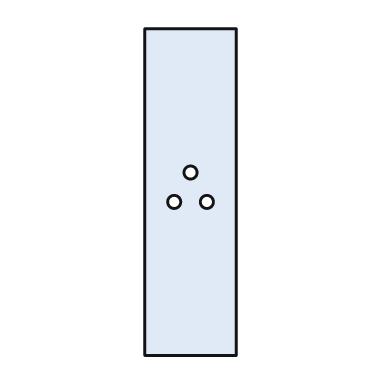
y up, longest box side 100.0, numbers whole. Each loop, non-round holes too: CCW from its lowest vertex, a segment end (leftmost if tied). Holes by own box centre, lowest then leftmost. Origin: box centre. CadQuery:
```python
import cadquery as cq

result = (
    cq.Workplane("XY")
    .moveTo(-14.0, -50.0)
    .lineTo(14.0, -50.0)
    .lineTo(14.0, 50.0)
    .lineTo(-14.0, 50.0)
    .close()
    .moveTo(-5.0, -3.0)
    .circle(2.0)
    .moveTo(5.0, -3.0)
    .circle(2.0)
    .moveTo(0.0, 6.0)
    .circle(2.0)
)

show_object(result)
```